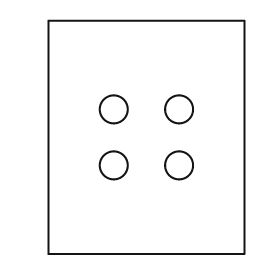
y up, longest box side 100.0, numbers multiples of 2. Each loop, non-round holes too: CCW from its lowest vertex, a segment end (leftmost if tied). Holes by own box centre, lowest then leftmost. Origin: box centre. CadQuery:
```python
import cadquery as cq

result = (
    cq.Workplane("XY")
    .moveTo(-42.0, -50.0)
    .lineTo(42.0, -50.0)
    .lineTo(42.0, 50.0)
    .lineTo(-42.0, 50.0)
    .close()
    .moveTo(-14.0, -12.0)
    .circle(6.0)
    .moveTo(14.0, -12.0)
    .circle(6.0)
    .moveTo(-14.0, 12.0)
    .circle(6.0)
    .moveTo(14.0, 12.0)
    .circle(6.0)
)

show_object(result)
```